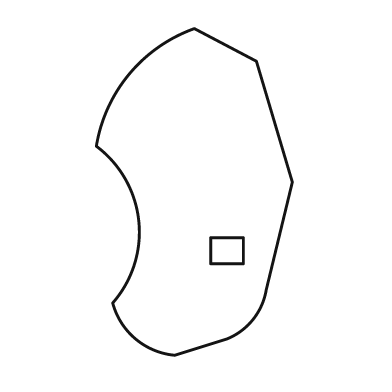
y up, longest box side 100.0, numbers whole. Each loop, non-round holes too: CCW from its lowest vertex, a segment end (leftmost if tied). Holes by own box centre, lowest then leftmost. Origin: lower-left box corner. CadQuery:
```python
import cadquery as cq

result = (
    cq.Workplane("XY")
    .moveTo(24.0, 0.0)
    .lineTo(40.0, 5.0)
    .threePointArc((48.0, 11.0), (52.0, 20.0))
    .lineTo(60.0, 53.0)
    .lineTo(49.0, 90.0)
    .lineTo(30.0, 100.0)
    .threePointArc((10.0, 86.0), (0.0, 64.0))
    .threePointArc((13.0, 41.0), (5.0, 16.0))
    .threePointArc((12.0, 5.0), (24.0, 0.0))
    .close()
    .moveTo(35.0, 28.0)
    .lineTo(45.0, 28.0)
    .lineTo(45.0, 36.0)
    .lineTo(35.0, 36.0)
    .close()
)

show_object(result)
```